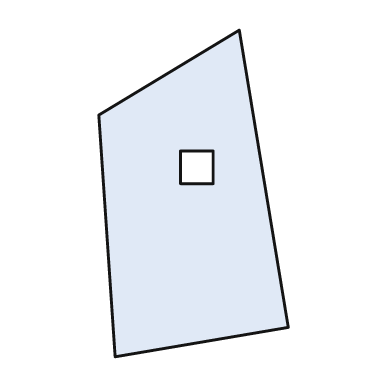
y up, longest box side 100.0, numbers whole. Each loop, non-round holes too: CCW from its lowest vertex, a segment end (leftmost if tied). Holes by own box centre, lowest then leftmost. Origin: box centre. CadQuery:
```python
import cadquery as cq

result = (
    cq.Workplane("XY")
    .moveTo(-24.0, -50.0)
    .lineTo(29.0, -41.0)
    .lineTo(14.0, 50.0)
    .lineTo(-29.0, 24.0)
    .close()
    .moveTo(-4.0, 3.0)
    .lineTo(6.0, 3.0)
    .lineTo(6.0, 13.0)
    .lineTo(-4.0, 13.0)
    .close()
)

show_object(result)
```